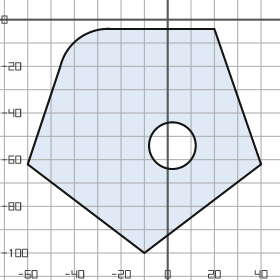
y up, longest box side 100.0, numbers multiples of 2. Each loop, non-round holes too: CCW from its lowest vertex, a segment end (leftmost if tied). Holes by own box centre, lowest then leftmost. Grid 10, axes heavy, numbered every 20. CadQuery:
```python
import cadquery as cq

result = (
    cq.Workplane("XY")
    .moveTo(-10.0, -100.0)
    .lineTo(40.0, -62.0)
    .lineTo(20.0, -4.0)
    .lineTo(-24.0, -4.0)
    .threePointArc((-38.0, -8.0), (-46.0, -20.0))
    .lineTo(-60.0, -62.0)
    .close()
    .moveTo(2.0, -54.0)
    .circle(10.0)
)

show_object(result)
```